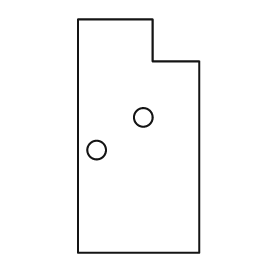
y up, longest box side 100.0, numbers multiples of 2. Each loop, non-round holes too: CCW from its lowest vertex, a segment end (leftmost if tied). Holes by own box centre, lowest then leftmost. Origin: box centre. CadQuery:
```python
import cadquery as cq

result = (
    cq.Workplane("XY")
    .moveTo(-26.0, -50.0)
    .lineTo(26.0, -50.0)
    .lineTo(26.0, 32.0)
    .lineTo(6.0, 32.0)
    .lineTo(6.0, 50.0)
    .lineTo(-26.0, 50.0)
    .close()
    .moveTo(-18.0, -6.0)
    .circle(4.0)
    .moveTo(2.0, 8.0)
    .circle(4.0)
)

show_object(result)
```